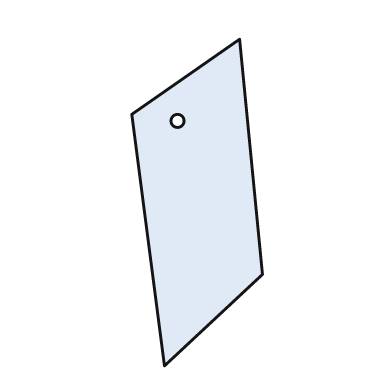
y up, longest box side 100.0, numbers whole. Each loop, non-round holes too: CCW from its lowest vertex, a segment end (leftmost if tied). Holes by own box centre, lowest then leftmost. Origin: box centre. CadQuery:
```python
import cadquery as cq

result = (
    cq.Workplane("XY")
    .moveTo(-10.0, -50.0)
    .lineTo(20.0, -22.0)
    .lineTo(13.0, 50.0)
    .lineTo(-20.0, 27.0)
    .close()
    .moveTo(-6.0, 25.0)
    .circle(2.0)
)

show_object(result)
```